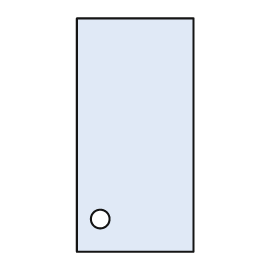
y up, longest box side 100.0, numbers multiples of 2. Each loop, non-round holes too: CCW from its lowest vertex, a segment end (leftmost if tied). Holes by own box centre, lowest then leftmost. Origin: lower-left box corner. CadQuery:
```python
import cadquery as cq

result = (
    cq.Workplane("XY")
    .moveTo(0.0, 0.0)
    .lineTo(50.0, 0.0)
    .lineTo(50.0, 100.0)
    .lineTo(0.0, 100.0)
    .close()
    .moveTo(10.0, 14.0)
    .circle(4.0)
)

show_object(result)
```